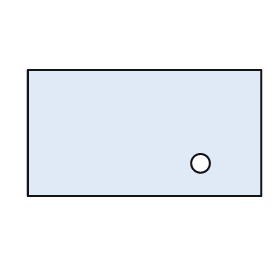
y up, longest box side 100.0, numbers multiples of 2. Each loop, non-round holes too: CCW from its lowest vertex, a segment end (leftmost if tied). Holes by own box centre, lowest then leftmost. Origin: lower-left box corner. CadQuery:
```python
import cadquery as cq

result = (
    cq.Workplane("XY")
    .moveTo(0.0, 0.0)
    .lineTo(100.0, 0.0)
    .lineTo(100.0, 54.0)
    .lineTo(0.0, 54.0)
    .close()
    .moveTo(74.0, 14.0)
    .circle(4.0)
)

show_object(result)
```